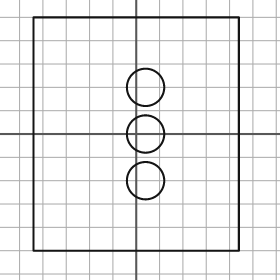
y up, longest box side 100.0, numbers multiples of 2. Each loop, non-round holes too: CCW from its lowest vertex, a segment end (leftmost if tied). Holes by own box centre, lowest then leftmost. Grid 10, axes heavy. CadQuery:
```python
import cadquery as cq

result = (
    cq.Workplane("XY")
    .moveTo(-44.0, -50.0)
    .lineTo(44.0, -50.0)
    .lineTo(44.0, 50.0)
    .lineTo(-44.0, 50.0)
    .close()
    .moveTo(4.0, -20.0)
    .circle(8.0)
    .moveTo(4.0, 0.0)
    .circle(8.0)
    .moveTo(4.0, 20.0)
    .circle(8.0)
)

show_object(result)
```